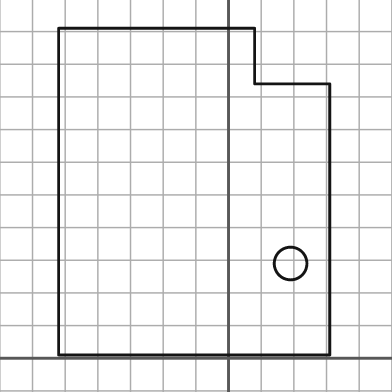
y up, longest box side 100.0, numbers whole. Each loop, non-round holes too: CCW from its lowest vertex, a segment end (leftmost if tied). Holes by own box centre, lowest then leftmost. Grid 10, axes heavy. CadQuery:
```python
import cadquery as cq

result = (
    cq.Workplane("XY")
    .moveTo(-52.0, 1.0)
    .lineTo(31.0, 1.0)
    .lineTo(31.0, 84.0)
    .lineTo(8.0, 84.0)
    .lineTo(8.0, 101.0)
    .lineTo(-52.0, 101.0)
    .close()
    .moveTo(19.0, 29.0)
    .circle(5.0)
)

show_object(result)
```